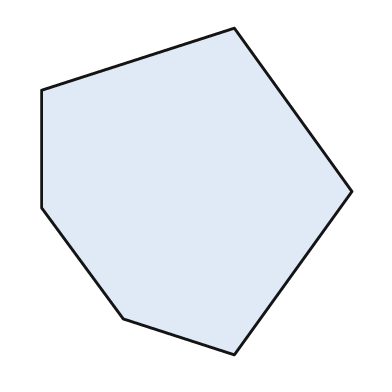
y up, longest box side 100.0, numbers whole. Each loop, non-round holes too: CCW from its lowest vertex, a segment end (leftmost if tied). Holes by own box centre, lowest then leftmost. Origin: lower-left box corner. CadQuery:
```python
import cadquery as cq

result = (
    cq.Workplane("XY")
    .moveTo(59.0, 0.0)
    .lineTo(95.0, 50.0)
    .lineTo(59.0, 100.0)
    .lineTo(0.0, 81.0)
    .lineTo(0.0, 45.0)
    .lineTo(25.0, 11.0)
    .close()
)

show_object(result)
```